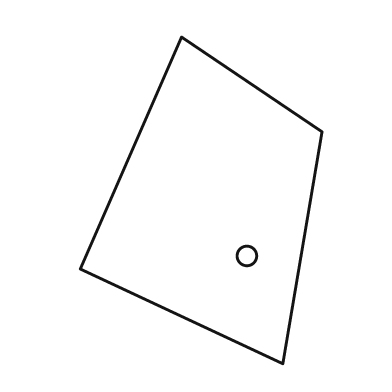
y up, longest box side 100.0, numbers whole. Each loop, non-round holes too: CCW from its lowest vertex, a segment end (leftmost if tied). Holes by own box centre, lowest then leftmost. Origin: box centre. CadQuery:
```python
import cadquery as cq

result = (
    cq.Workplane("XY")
    .moveTo(25.0, -50.0)
    .lineTo(37.0, 21.0)
    .lineTo(-6.0, 50.0)
    .lineTo(-37.0, -21.0)
    .close()
    .moveTo(14.0, -17.0)
    .circle(3.0)
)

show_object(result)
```